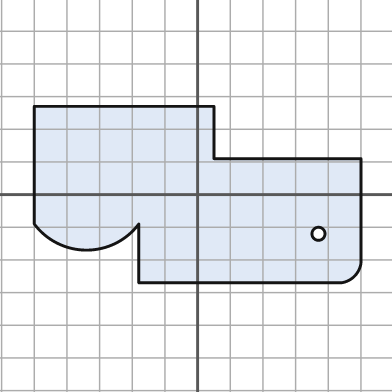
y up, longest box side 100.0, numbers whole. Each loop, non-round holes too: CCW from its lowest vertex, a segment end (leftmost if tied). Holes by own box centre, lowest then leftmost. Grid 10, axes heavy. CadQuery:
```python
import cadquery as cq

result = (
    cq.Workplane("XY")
    .moveTo(-18.0, -27.0)
    .lineTo(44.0, -27.0)
    .threePointArc((48.0, -25.0), (50.0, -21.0))
    .lineTo(50.0, 11.0)
    .lineTo(5.0, 11.0)
    .lineTo(5.0, 27.0)
    .lineTo(-50.0, 27.0)
    .lineTo(-50.0, -9.0)
    .threePointArc((-34.0, -17.0), (-18.0, -9.0))
    .close()
    .moveTo(37.0, -12.0)
    .circle(2.0)
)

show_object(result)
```